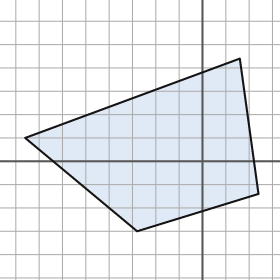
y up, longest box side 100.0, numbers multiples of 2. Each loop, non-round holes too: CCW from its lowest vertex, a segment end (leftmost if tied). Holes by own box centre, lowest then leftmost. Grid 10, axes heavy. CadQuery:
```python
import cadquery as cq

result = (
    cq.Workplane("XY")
    .moveTo(-28.0, -30.0)
    .lineTo(24.0, -14.0)
    .lineTo(16.0, 44.0)
    .lineTo(-76.0, 10.0)
    .close()
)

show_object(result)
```